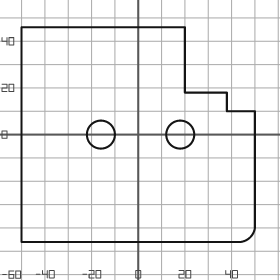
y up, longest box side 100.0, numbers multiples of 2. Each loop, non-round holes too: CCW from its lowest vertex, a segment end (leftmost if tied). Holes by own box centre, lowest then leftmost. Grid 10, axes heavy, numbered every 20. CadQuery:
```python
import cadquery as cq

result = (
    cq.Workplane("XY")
    .moveTo(-50.0, -46.0)
    .lineTo(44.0, -46.0)
    .threePointArc((48.0, -44.0), (50.0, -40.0))
    .lineTo(50.0, 10.0)
    .lineTo(38.0, 10.0)
    .lineTo(38.0, 18.0)
    .lineTo(20.0, 18.0)
    .lineTo(20.0, 46.0)
    .lineTo(-50.0, 46.0)
    .close()
    .moveTo(-16.0, 0.0)
    .circle(6.0)
    .moveTo(18.0, 0.0)
    .circle(6.0)
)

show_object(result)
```